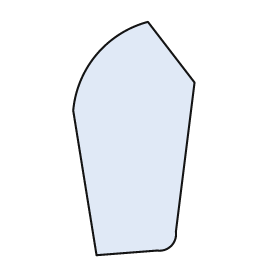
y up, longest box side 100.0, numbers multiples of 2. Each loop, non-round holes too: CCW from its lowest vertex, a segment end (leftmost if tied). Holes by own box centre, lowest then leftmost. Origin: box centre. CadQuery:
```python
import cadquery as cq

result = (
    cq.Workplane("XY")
    .moveTo(-16.0, -50.0)
    .lineTo(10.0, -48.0)
    .threePointArc((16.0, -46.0), (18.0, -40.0))
    .lineTo(26.0, 24.0)
    .lineTo(6.0, 50.0)
    .threePointArc((-16.0, 36.0), (-26.0, 12.0))
    .close()
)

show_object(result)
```